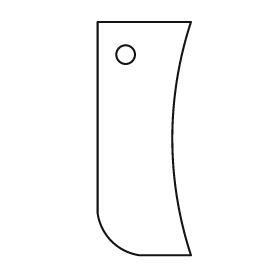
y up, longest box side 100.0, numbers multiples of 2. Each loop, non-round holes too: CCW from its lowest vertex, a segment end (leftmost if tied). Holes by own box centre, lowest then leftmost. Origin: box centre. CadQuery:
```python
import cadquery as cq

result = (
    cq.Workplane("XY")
    .moveTo(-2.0, -50.0)
    .lineTo(20.0, -50.0)
    .threePointArc((12.0, 0.0), (20.0, 50.0))
    .lineTo(-20.0, 50.0)
    .lineTo(-20.0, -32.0)
    .threePointArc((-14.0, -44.0), (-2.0, -50.0))
    .close()
    .moveTo(-8.0, 36.0)
    .circle(4.0)
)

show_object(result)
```